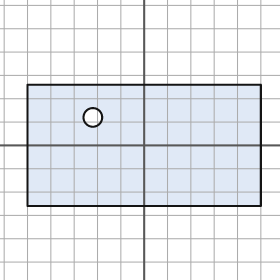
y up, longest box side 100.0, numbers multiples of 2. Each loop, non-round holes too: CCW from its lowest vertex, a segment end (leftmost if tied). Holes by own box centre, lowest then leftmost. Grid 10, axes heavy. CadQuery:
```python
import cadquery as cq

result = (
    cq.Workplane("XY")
    .moveTo(-50.0, -26.0)
    .lineTo(50.0, -26.0)
    .lineTo(50.0, 26.0)
    .lineTo(-50.0, 26.0)
    .close()
    .moveTo(-22.0, 12.0)
    .circle(4.0)
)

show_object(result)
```